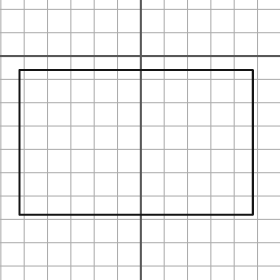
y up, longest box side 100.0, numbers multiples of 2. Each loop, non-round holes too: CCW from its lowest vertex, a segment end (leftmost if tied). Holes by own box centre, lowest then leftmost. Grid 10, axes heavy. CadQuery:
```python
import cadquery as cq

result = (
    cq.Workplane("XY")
    .moveTo(-52.0, -68.0)
    .lineTo(48.0, -68.0)
    .lineTo(48.0, -6.0)
    .lineTo(-52.0, -6.0)
    .close()
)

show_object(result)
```